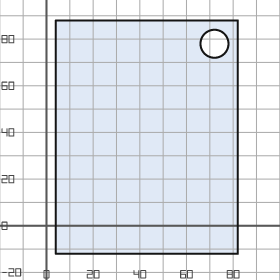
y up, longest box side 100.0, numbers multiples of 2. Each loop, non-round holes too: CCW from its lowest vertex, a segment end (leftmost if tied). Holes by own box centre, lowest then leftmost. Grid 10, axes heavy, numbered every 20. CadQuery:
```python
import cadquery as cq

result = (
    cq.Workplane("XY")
    .moveTo(4.0, -12.0)
    .lineTo(82.0, -12.0)
    .lineTo(82.0, 88.0)
    .lineTo(4.0, 88.0)
    .close()
    .moveTo(72.0, 78.0)
    .circle(6.0)
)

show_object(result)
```